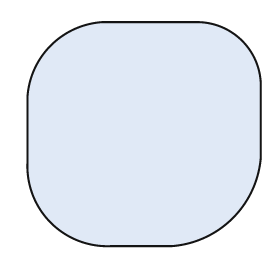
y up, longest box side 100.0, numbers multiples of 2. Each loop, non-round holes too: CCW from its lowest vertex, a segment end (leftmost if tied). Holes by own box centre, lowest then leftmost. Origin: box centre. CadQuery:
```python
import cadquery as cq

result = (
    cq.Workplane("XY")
    .moveTo(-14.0, -48.0)
    .lineTo(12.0, -48.0)
    .threePointArc((38.0, -36.0), (50.0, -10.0))
    .lineTo(50.0, 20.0)
    .threePointArc((42.0, 40.0), (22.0, 48.0))
    .lineTo(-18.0, 48.0)
    .threePointArc((-40.0, 38.0), (-50.0, 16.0))
    .lineTo(-50.0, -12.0)
    .threePointArc((-40.0, -38.0), (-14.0, -48.0))
    .close()
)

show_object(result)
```